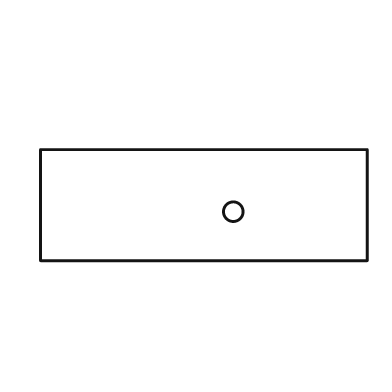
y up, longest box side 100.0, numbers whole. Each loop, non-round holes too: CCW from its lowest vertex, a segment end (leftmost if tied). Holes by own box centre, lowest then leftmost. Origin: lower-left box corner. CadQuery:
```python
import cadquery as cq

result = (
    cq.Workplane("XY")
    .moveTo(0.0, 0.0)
    .lineTo(100.0, 0.0)
    .lineTo(100.0, 34.0)
    .lineTo(0.0, 34.0)
    .close()
    .moveTo(59.0, 15.0)
    .circle(3.0)
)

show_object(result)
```